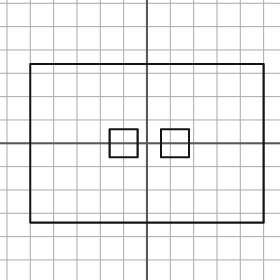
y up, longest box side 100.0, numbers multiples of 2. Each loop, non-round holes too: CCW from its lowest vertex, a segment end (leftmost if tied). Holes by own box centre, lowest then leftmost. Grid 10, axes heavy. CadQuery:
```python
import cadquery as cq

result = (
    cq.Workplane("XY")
    .moveTo(-50.0, -34.0)
    .lineTo(50.0, -34.0)
    .lineTo(50.0, 34.0)
    .lineTo(-50.0, 34.0)
    .close()
    .moveTo(-16.0, -6.0)
    .lineTo(-4.0, -6.0)
    .lineTo(-4.0, 6.0)
    .lineTo(-16.0, 6.0)
    .close()
    .moveTo(6.0, -6.0)
    .lineTo(18.0, -6.0)
    .lineTo(18.0, 6.0)
    .lineTo(6.0, 6.0)
    .close()
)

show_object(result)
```